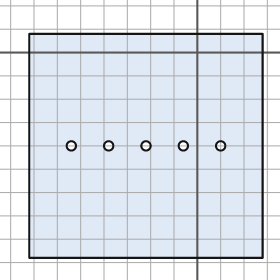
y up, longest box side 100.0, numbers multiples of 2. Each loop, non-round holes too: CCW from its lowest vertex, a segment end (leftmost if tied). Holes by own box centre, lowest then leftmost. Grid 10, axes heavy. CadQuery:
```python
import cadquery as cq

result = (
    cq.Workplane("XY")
    .moveTo(-72.0, -88.0)
    .lineTo(28.0, -88.0)
    .lineTo(28.0, 8.0)
    .lineTo(-72.0, 8.0)
    .close()
    .moveTo(-54.0, -40.0)
    .circle(2.0)
    .moveTo(-38.0, -40.0)
    .circle(2.0)
    .moveTo(-22.0, -40.0)
    .circle(2.0)
    .moveTo(-6.0, -40.0)
    .circle(2.0)
    .moveTo(10.0, -40.0)
    .circle(2.0)
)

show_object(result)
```